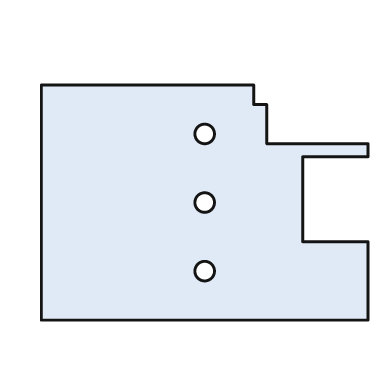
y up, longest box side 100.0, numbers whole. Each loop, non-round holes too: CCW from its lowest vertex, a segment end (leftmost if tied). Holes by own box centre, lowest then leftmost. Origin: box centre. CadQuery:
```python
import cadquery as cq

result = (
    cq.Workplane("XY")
    .moveTo(-50.0, -36.0)
    .lineTo(50.0, -36.0)
    .lineTo(50.0, -12.0)
    .lineTo(30.0, -12.0)
    .lineTo(30.0, 14.0)
    .lineTo(50.0, 14.0)
    .lineTo(50.0, 18.0)
    .lineTo(19.0, 18.0)
    .lineTo(19.0, 30.0)
    .lineTo(15.0, 30.0)
    .lineTo(15.0, 36.0)
    .lineTo(-50.0, 36.0)
    .close()
    .moveTo(0.0, -21.0)
    .circle(3.0)
    .moveTo(0.0, 0.0)
    .circle(3.0)
    .moveTo(0.0, 21.0)
    .circle(3.0)
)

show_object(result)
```